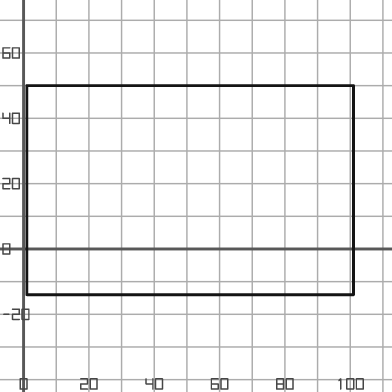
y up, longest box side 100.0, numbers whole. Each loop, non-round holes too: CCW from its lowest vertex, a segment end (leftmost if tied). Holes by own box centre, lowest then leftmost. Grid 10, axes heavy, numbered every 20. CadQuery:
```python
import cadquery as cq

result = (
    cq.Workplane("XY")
    .moveTo(1.0, -14.0)
    .lineTo(101.0, -14.0)
    .lineTo(101.0, 50.0)
    .lineTo(1.0, 50.0)
    .close()
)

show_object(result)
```